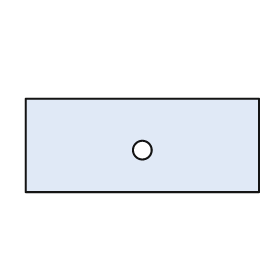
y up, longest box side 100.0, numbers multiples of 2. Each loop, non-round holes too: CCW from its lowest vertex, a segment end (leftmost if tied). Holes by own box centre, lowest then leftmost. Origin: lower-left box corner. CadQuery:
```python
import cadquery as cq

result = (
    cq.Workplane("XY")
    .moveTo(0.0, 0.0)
    .lineTo(100.0, 0.0)
    .lineTo(100.0, 40.0)
    .lineTo(0.0, 40.0)
    .close()
    .moveTo(50.0, 18.0)
    .circle(4.0)
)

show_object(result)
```